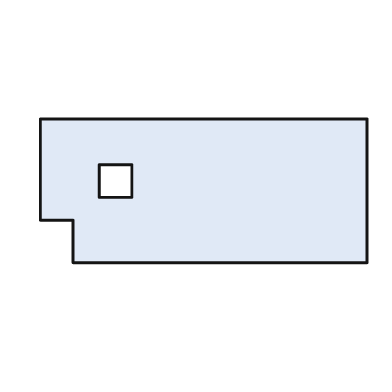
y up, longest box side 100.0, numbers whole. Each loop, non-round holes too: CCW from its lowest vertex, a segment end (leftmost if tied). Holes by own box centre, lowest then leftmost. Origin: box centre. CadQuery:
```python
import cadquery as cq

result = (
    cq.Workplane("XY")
    .moveTo(-40.0, -22.0)
    .lineTo(50.0, -22.0)
    .lineTo(50.0, 22.0)
    .lineTo(-50.0, 22.0)
    .lineTo(-50.0, -9.0)
    .lineTo(-40.0, -9.0)
    .close()
    .moveTo(-32.0, -2.0)
    .lineTo(-22.0, -2.0)
    .lineTo(-22.0, 8.0)
    .lineTo(-32.0, 8.0)
    .close()
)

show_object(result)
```